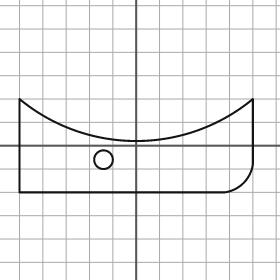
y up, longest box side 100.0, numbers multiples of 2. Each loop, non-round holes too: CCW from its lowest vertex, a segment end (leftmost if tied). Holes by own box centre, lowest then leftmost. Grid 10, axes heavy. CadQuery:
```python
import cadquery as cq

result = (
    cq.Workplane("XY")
    .moveTo(-50.0, -20.0)
    .lineTo(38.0, -20.0)
    .threePointArc((46.0, -16.0), (50.0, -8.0))
    .lineTo(50.0, 20.0)
    .threePointArc((0.0, 2.0), (-50.0, 20.0))
    .close()
    .moveTo(-14.0, -6.0)
    .circle(4.0)
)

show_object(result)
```